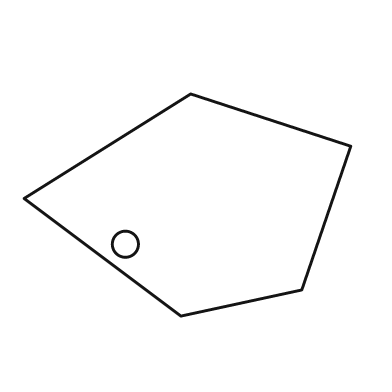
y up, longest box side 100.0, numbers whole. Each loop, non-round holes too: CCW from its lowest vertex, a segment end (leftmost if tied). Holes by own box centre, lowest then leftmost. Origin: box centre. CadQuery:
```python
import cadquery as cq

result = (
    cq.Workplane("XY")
    .moveTo(-2.0, -34.0)
    .lineTo(35.0, -26.0)
    .lineTo(50.0, 18.0)
    .lineTo(1.0, 34.0)
    .lineTo(-50.0, 2.0)
    .close()
    .moveTo(-19.0, -12.0)
    .circle(4.0)
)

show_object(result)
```